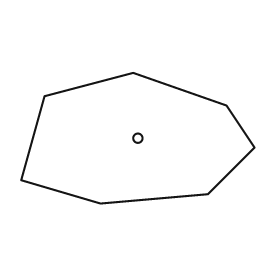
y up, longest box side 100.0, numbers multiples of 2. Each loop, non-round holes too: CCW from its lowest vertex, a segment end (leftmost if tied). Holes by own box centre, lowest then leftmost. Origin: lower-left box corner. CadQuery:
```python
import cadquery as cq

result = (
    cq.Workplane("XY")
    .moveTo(34.0, 0.0)
    .lineTo(80.0, 4.0)
    .lineTo(100.0, 24.0)
    .lineTo(88.0, 42.0)
    .lineTo(48.0, 56.0)
    .lineTo(10.0, 46.0)
    .lineTo(0.0, 10.0)
    .close()
    .moveTo(50.0, 28.0)
    .circle(2.0)
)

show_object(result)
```